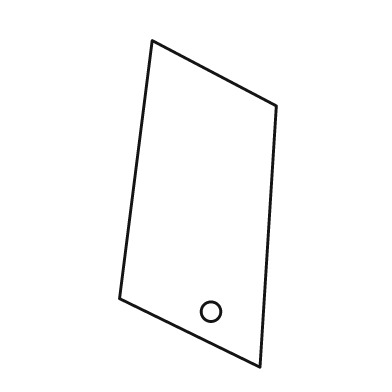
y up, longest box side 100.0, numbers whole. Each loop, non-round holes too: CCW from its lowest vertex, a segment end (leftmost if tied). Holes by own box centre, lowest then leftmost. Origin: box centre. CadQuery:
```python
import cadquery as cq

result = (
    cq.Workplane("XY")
    .moveTo(19.0, -50.0)
    .lineTo(24.0, 30.0)
    .lineTo(-14.0, 50.0)
    .lineTo(-24.0, -29.0)
    .close()
    .moveTo(4.0, -33.0)
    .circle(3.0)
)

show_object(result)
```